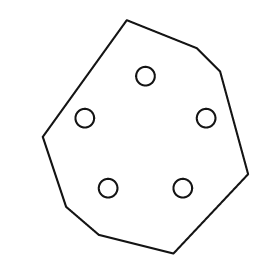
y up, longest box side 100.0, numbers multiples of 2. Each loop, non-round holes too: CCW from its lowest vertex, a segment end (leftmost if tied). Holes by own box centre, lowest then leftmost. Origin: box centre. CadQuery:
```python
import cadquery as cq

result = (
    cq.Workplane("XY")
    .moveTo(12.0, -50.0)
    .lineTo(44.0, -16.0)
    .lineTo(32.0, 28.0)
    .lineTo(22.0, 38.0)
    .lineTo(-8.0, 50.0)
    .lineTo(-44.0, 0.0)
    .lineTo(-34.0, -30.0)
    .lineTo(-20.0, -42.0)
    .close()
    .moveTo(-16.0, -22.0)
    .circle(4.0)
    .moveTo(16.0, -22.0)
    .circle(4.0)
    .moveTo(-26.0, 8.0)
    .circle(4.0)
    .moveTo(26.0, 8.0)
    .circle(4.0)
    .moveTo(0.0, 26.0)
    .circle(4.0)
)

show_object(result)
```